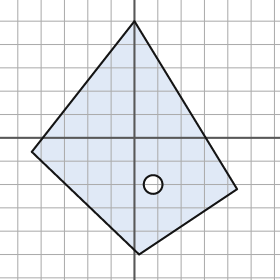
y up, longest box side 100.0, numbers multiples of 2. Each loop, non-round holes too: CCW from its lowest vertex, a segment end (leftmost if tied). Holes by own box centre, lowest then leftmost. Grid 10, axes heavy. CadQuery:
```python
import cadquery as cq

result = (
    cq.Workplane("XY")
    .moveTo(2.0, -50.0)
    .lineTo(44.0, -22.0)
    .lineTo(0.0, 50.0)
    .lineTo(-44.0, -6.0)
    .close()
    .moveTo(8.0, -20.0)
    .circle(4.0)
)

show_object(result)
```